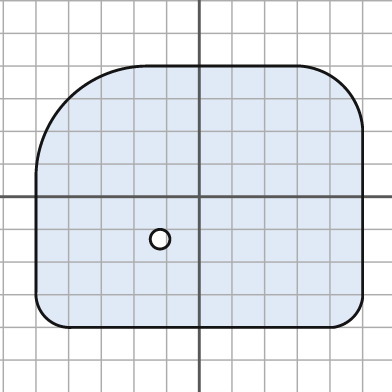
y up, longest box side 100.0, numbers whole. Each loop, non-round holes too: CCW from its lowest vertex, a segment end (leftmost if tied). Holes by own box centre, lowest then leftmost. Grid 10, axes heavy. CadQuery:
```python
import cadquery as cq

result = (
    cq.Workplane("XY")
    .moveTo(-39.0, -40.0)
    .lineTo(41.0, -40.0)
    .threePointArc((47.0, -37.0), (50.0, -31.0))
    .lineTo(50.0, 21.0)
    .threePointArc((44.0, 34.0), (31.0, 40.0))
    .lineTo(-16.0, 40.0)
    .threePointArc((-40.0, 30.0), (-50.0, 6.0))
    .lineTo(-50.0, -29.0)
    .threePointArc((-47.0, -37.0), (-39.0, -40.0))
    .close()
    .moveTo(-12.0, -13.0)
    .circle(3.0)
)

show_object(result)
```